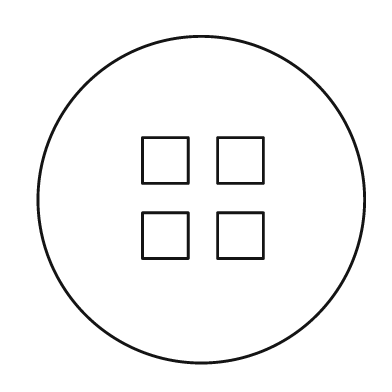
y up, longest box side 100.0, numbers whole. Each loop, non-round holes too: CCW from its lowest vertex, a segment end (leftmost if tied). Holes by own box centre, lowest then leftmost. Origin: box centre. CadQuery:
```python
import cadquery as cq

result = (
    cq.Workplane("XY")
    .moveTo(0.0, 0.0)
    .circle(50.0)
    .moveTo(-18.0, -18.0)
    .lineTo(-4.0, -18.0)
    .lineTo(-4.0, -4.0)
    .lineTo(-18.0, -4.0)
    .close()
    .moveTo(5.0, -18.0)
    .lineTo(19.0, -18.0)
    .lineTo(19.0, -4.0)
    .lineTo(5.0, -4.0)
    .close()
    .moveTo(-18.0, 5.0)
    .lineTo(-4.0, 5.0)
    .lineTo(-4.0, 19.0)
    .lineTo(-18.0, 19.0)
    .close()
    .moveTo(5.0, 5.0)
    .lineTo(19.0, 5.0)
    .lineTo(19.0, 19.0)
    .lineTo(5.0, 19.0)
    .close()
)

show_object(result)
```